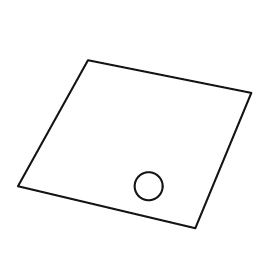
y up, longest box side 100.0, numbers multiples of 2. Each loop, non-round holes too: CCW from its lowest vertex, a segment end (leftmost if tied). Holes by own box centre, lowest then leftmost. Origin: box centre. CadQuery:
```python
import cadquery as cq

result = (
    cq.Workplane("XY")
    .moveTo(26.0, -36.0)
    .lineTo(50.0, 22.0)
    .lineTo(-20.0, 36.0)
    .lineTo(-50.0, -18.0)
    .close()
    .moveTo(6.0, -18.0)
    .circle(6.0)
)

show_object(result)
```